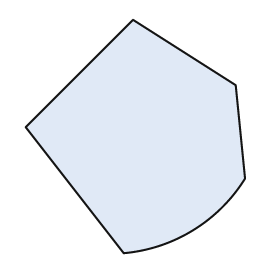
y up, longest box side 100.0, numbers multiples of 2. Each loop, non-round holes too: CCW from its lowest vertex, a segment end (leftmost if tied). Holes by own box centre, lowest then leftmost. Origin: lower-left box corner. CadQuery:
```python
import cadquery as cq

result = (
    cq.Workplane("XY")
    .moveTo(42.0, 0.0)
    .threePointArc((72.0, 10.0), (94.0, 32.0))
    .lineTo(90.0, 72.0)
    .lineTo(46.0, 100.0)
    .lineTo(0.0, 54.0)
    .close()
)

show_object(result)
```